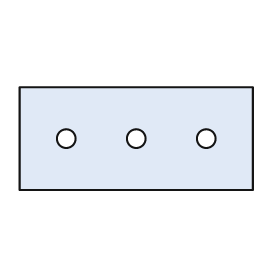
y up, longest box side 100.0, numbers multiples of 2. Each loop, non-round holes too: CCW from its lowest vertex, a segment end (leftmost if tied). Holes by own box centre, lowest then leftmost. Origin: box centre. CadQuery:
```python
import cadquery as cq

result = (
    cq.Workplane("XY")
    .moveTo(-50.0, -22.0)
    .lineTo(50.0, -22.0)
    .lineTo(50.0, 22.0)
    .lineTo(-50.0, 22.0)
    .close()
    .moveTo(-30.0, 0.0)
    .circle(4.0)
    .moveTo(0.0, 0.0)
    .circle(4.0)
    .moveTo(30.0, 0.0)
    .circle(4.0)
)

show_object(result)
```